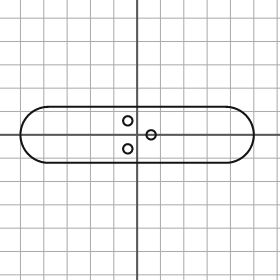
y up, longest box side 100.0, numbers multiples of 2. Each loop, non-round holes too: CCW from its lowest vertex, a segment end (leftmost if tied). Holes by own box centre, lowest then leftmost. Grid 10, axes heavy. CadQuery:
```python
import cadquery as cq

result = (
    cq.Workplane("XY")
    .moveTo(-38.0, -12.0)
    .lineTo(38.0, -12.0)
    .threePointArc((50.0, 0.0), (38.0, 12.0))
    .lineTo(-38.0, 12.0)
    .threePointArc((-50.0, 0.0), (-38.0, -12.0))
    .close()
    .moveTo(-4.0, -6.0)
    .circle(2.0)
    .moveTo(6.0, 0.0)
    .circle(2.0)
    .moveTo(-4.0, 6.0)
    .circle(2.0)
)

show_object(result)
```